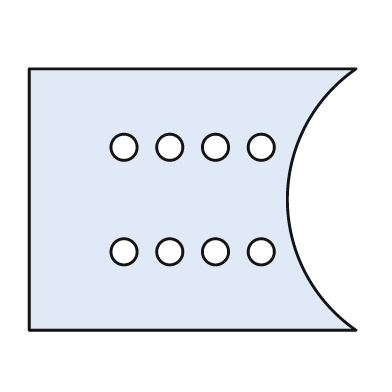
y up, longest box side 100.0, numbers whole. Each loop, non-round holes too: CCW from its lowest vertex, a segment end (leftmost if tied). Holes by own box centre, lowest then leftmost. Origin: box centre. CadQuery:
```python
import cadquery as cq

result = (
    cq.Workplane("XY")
    .moveTo(-50.0, -40.0)
    .lineTo(50.0, -40.0)
    .threePointArc((29.0, 0.0), (50.0, 40.0))
    .lineTo(-50.0, 40.0)
    .close()
    .moveTo(-21.0, -16.0)
    .circle(4.0)
    .moveTo(-7.0, -16.0)
    .circle(4.0)
    .moveTo(7.0, -16.0)
    .circle(4.0)
    .moveTo(21.0, -16.0)
    .circle(4.0)
    .moveTo(-21.0, 16.0)
    .circle(4.0)
    .moveTo(-7.0, 16.0)
    .circle(4.0)
    .moveTo(7.0, 16.0)
    .circle(4.0)
    .moveTo(21.0, 16.0)
    .circle(4.0)
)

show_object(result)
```